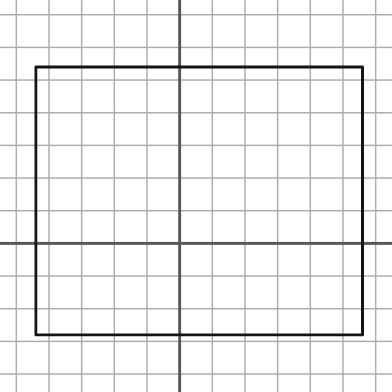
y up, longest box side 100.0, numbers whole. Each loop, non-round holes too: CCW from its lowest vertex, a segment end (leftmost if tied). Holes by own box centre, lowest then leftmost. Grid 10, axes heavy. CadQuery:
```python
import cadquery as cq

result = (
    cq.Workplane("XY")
    .moveTo(-44.0, -28.0)
    .lineTo(56.0, -28.0)
    .lineTo(56.0, 54.0)
    .lineTo(-44.0, 54.0)
    .close()
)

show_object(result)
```